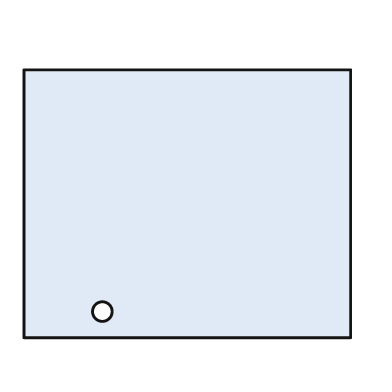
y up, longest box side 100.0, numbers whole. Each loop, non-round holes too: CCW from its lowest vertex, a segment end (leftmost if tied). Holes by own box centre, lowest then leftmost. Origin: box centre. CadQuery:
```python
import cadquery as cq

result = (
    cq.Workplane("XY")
    .moveTo(-50.0, -41.0)
    .lineTo(50.0, -41.0)
    .lineTo(50.0, 41.0)
    .lineTo(-50.0, 41.0)
    .close()
    .moveTo(-26.0, -33.0)
    .circle(3.0)
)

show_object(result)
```